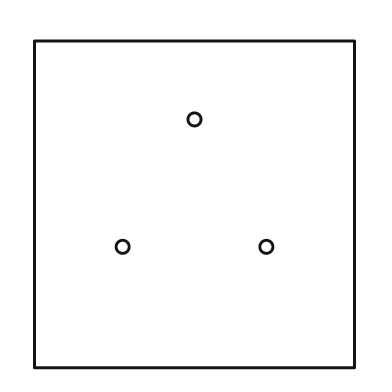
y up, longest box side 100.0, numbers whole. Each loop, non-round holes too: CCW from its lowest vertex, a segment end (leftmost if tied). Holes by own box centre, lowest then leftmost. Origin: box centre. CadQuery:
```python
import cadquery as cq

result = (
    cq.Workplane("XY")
    .moveTo(-49.0, -50.0)
    .lineTo(49.0, -50.0)
    .lineTo(49.0, 50.0)
    .lineTo(-49.0, 50.0)
    .close()
    .moveTo(-22.0, -13.0)
    .circle(2.0)
    .moveTo(22.0, -13.0)
    .circle(2.0)
    .moveTo(0.0, 26.0)
    .circle(2.0)
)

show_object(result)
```